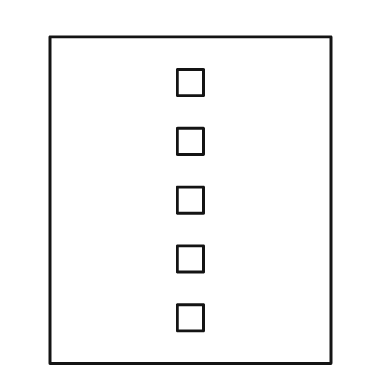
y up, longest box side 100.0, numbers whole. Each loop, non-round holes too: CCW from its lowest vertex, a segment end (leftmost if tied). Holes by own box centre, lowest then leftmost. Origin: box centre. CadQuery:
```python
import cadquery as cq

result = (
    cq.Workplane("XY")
    .moveTo(-43.0, -50.0)
    .lineTo(43.0, -50.0)
    .lineTo(43.0, 50.0)
    .lineTo(-43.0, 50.0)
    .close()
    .moveTo(-4.0, -40.0)
    .lineTo(4.0, -40.0)
    .lineTo(4.0, -32.0)
    .lineTo(-4.0, -32.0)
    .close()
    .moveTo(-4.0, -22.0)
    .lineTo(4.0, -22.0)
    .lineTo(4.0, -14.0)
    .lineTo(-4.0, -14.0)
    .close()
    .moveTo(-4.0, -4.0)
    .lineTo(4.0, -4.0)
    .lineTo(4.0, 4.0)
    .lineTo(-4.0, 4.0)
    .close()
    .moveTo(-4.0, 14.0)
    .lineTo(4.0, 14.0)
    .lineTo(4.0, 22.0)
    .lineTo(-4.0, 22.0)
    .close()
    .moveTo(-4.0, 32.0)
    .lineTo(4.0, 32.0)
    .lineTo(4.0, 40.0)
    .lineTo(-4.0, 40.0)
    .close()
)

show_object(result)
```